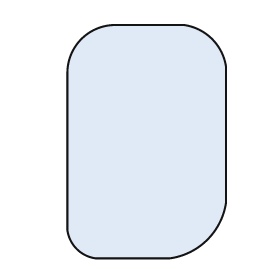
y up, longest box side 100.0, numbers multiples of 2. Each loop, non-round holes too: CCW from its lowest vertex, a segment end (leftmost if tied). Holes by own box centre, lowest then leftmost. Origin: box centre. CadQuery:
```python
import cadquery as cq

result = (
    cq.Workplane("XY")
    .moveTo(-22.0, -50.0)
    .lineTo(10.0, -50.0)
    .threePointArc((26.0, -42.0), (34.0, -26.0))
    .lineTo(34.0, 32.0)
    .threePointArc((28.0, 44.0), (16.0, 50.0))
    .lineTo(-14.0, 50.0)
    .threePointArc((-28.0, 44.0), (-34.0, 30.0))
    .lineTo(-34.0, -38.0)
    .threePointArc((-30.0, -46.0), (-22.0, -50.0))
    .close()
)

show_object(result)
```